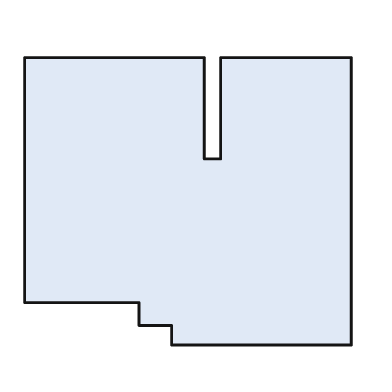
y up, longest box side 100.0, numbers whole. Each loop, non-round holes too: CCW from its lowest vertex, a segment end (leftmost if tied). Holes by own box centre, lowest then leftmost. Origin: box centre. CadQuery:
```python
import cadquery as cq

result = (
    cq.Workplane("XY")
    .moveTo(-5.0, -44.0)
    .lineTo(50.0, -44.0)
    .lineTo(50.0, 44.0)
    .lineTo(10.0, 44.0)
    .lineTo(10.0, 13.0)
    .lineTo(5.0, 13.0)
    .lineTo(5.0, 44.0)
    .lineTo(-50.0, 44.0)
    .lineTo(-50.0, -31.0)
    .lineTo(-15.0, -31.0)
    .lineTo(-15.0, -38.0)
    .lineTo(-5.0, -38.0)
    .close()
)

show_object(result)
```